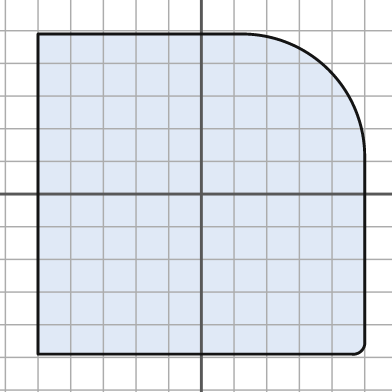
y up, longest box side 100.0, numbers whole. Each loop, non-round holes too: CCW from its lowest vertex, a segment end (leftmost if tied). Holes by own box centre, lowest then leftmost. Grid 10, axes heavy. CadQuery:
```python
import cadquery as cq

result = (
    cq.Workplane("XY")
    .moveTo(-50.0, -49.0)
    .lineTo(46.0, -49.0)
    .threePointArc((49.0, -48.0), (50.0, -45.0))
    .lineTo(50.0, 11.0)
    .threePointArc((39.0, 38.0), (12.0, 49.0))
    .lineTo(-50.0, 49.0)
    .close()
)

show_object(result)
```